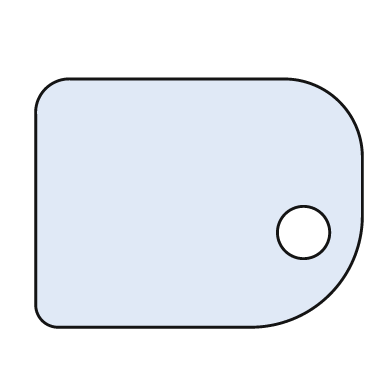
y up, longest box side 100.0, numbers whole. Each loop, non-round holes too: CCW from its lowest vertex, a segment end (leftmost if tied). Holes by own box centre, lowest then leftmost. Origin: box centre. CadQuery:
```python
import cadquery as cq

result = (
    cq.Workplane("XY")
    .moveTo(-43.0, -38.0)
    .lineTo(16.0, -38.0)
    .threePointArc((40.0, -28.0), (50.0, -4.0))
    .lineTo(50.0, 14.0)
    .threePointArc((43.0, 31.0), (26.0, 38.0))
    .lineTo(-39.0, 38.0)
    .threePointArc((-47.0, 35.0), (-50.0, 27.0))
    .lineTo(-50.0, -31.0)
    .threePointArc((-48.0, -36.0), (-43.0, -38.0))
    .close()
    .moveTo(32.0, -9.0)
    .circle(8.0)
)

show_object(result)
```